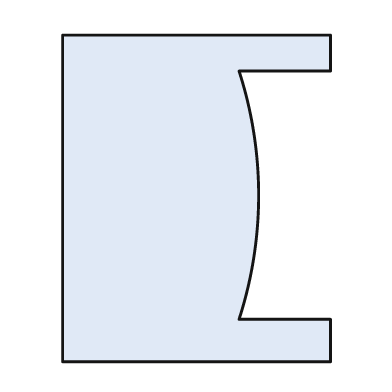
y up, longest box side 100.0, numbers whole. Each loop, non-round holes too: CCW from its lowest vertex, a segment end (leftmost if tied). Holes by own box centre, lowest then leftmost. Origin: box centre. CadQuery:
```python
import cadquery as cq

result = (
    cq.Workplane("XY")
    .moveTo(-41.0, -50.0)
    .lineTo(41.0, -50.0)
    .lineTo(41.0, -37.0)
    .lineTo(13.0, -37.0)
    .threePointArc((19.0, 1.0), (13.0, 39.0))
    .lineTo(41.0, 39.0)
    .lineTo(41.0, 50.0)
    .lineTo(-41.0, 50.0)
    .close()
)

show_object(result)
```